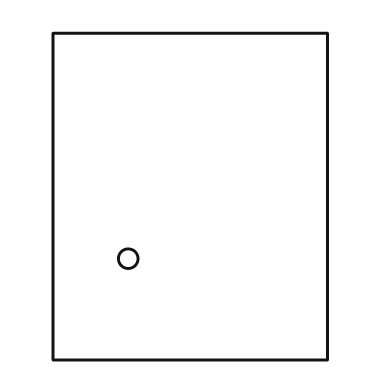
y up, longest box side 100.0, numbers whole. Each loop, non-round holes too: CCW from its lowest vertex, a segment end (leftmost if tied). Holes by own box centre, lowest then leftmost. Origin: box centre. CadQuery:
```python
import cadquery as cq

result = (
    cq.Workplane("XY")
    .moveTo(-42.0, -50.0)
    .lineTo(42.0, -50.0)
    .lineTo(42.0, 50.0)
    .lineTo(-42.0, 50.0)
    .close()
    .moveTo(-19.0, -19.0)
    .circle(3.0)
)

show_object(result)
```